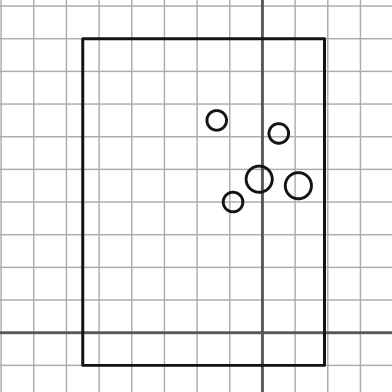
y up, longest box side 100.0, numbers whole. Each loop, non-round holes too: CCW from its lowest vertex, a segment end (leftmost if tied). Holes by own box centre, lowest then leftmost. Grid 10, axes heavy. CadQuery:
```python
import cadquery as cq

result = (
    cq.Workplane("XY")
    .moveTo(-55.0, -10.0)
    .lineTo(19.0, -10.0)
    .lineTo(19.0, 90.0)
    .lineTo(-55.0, 90.0)
    .close()
    .moveTo(-9.0, 40.0)
    .circle(3.0)
    .moveTo(11.0, 45.0)
    .circle(4.0)
    .moveTo(-1.0, 47.0)
    .circle(4.0)
    .moveTo(5.0, 61.0)
    .circle(3.0)
    .moveTo(-14.0, 65.0)
    .circle(3.0)
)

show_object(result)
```